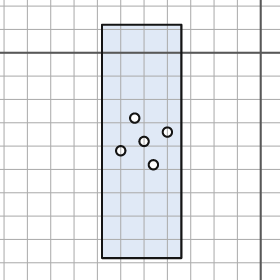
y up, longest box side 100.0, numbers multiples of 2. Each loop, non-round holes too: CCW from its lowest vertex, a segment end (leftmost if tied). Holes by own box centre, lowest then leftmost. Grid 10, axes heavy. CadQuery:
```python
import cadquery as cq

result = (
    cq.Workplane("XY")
    .moveTo(-68.0, -88.0)
    .lineTo(-34.0, -88.0)
    .lineTo(-34.0, 12.0)
    .lineTo(-68.0, 12.0)
    .close()
    .moveTo(-46.0, -48.0)
    .circle(2.0)
    .moveTo(-60.0, -42.0)
    .circle(2.0)
    .moveTo(-50.0, -38.0)
    .circle(2.0)
    .moveTo(-40.0, -34.0)
    .circle(2.0)
    .moveTo(-54.0, -28.0)
    .circle(2.0)
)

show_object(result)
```